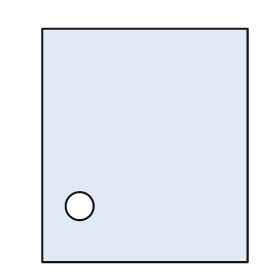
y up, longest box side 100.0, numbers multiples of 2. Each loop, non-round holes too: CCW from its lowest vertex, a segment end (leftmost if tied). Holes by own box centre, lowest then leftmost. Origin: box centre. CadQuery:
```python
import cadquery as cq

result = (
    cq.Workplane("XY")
    .moveTo(-44.0, -50.0)
    .lineTo(44.0, -50.0)
    .lineTo(44.0, 50.0)
    .lineTo(-44.0, 50.0)
    .close()
    .moveTo(-28.0, -26.0)
    .circle(6.0)
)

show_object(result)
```